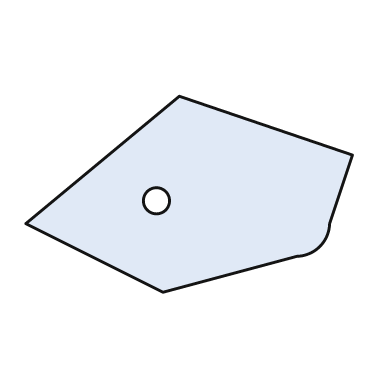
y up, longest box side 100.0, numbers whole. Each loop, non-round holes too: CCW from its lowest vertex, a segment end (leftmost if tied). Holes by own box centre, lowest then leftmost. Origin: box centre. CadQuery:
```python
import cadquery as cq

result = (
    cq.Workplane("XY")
    .moveTo(-8.0, -30.0)
    .lineTo(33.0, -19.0)
    .threePointArc((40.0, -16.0), (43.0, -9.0))
    .lineTo(50.0, 12.0)
    .lineTo(-3.0, 30.0)
    .lineTo(-50.0, -9.0)
    .close()
    .moveTo(-10.0, -2.0)
    .circle(4.0)
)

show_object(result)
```